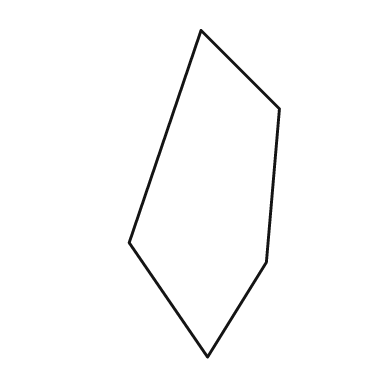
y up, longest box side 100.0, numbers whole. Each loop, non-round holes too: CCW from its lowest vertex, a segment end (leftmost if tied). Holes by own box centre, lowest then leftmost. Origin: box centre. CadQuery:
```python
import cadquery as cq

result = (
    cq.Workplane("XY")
    .moveTo(1.0, -50.0)
    .lineTo(19.0, -21.0)
    .lineTo(23.0, 26.0)
    .lineTo(-1.0, 50.0)
    .lineTo(-23.0, -15.0)
    .close()
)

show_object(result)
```